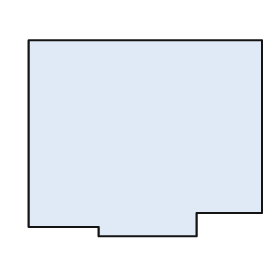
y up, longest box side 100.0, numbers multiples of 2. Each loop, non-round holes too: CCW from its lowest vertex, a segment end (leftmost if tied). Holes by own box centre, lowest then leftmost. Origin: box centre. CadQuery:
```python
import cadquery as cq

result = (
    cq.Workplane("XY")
    .moveTo(-20.0, -42.0)
    .lineTo(22.0, -42.0)
    .lineTo(22.0, -32.0)
    .lineTo(50.0, -32.0)
    .lineTo(50.0, 42.0)
    .lineTo(-50.0, 42.0)
    .lineTo(-50.0, -38.0)
    .lineTo(-20.0, -38.0)
    .close()
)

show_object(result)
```